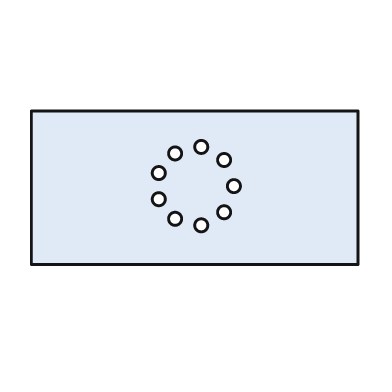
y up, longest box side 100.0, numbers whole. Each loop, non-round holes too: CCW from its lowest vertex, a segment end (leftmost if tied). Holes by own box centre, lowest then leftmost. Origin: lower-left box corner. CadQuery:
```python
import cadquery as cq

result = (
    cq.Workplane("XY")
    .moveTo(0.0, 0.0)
    .lineTo(100.0, 0.0)
    .lineTo(100.0, 47.0)
    .lineTo(0.0, 47.0)
    .close()
    .moveTo(52.0, 12.0)
    .circle(2.0)
    .moveTo(44.0, 14.0)
    .circle(2.0)
    .moveTo(59.0, 16.0)
    .circle(2.0)
    .moveTo(39.0, 20.0)
    .circle(2.0)
    .moveTo(62.0, 24.0)
    .circle(2.0)
    .moveTo(39.0, 28.0)
    .circle(2.0)
    .moveTo(59.0, 32.0)
    .circle(2.0)
    .moveTo(44.0, 34.0)
    .circle(2.0)
    .moveTo(52.0, 36.0)
    .circle(2.0)
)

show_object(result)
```